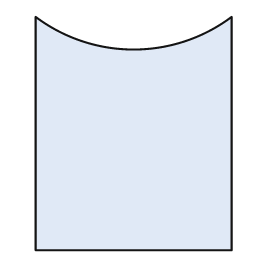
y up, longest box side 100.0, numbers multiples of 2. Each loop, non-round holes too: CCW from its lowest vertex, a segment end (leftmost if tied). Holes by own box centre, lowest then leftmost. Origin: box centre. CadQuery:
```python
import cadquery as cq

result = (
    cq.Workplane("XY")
    .moveTo(-42.0, -50.0)
    .lineTo(42.0, -50.0)
    .lineTo(42.0, 50.0)
    .threePointArc((0.0, 36.0), (-42.0, 50.0))
    .close()
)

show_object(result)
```